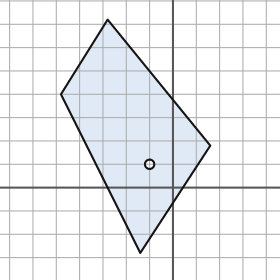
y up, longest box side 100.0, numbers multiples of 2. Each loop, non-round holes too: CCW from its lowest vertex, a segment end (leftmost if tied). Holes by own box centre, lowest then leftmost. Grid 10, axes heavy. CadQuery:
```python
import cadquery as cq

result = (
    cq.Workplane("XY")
    .moveTo(-14.0, -28.0)
    .lineTo(16.0, 18.0)
    .lineTo(-28.0, 72.0)
    .lineTo(-48.0, 40.0)
    .close()
    .moveTo(-10.0, 10.0)
    .circle(2.0)
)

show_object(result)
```